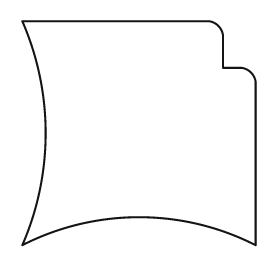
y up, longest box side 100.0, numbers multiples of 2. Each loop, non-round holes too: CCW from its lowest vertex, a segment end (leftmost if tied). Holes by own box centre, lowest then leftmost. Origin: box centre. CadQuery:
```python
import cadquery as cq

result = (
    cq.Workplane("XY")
    .moveTo(-50.0, -48.0)
    .threePointArc((0.0, -36.0), (50.0, -48.0))
    .lineTo(50.0, 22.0)
    .threePointArc((48.0, 26.0), (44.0, 28.0))
    .lineTo(36.0, 28.0)
    .lineTo(36.0, 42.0)
    .threePointArc((34.0, 46.0), (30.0, 48.0))
    .lineTo(-50.0, 48.0)
    .threePointArc((-40.0, 0.0), (-50.0, -48.0))
    .close()
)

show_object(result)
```